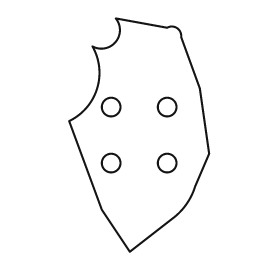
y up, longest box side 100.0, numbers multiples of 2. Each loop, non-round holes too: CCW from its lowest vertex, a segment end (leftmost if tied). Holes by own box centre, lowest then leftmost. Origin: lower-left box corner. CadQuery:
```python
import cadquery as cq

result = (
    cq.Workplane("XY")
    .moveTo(26.0, 0.0)
    .lineTo(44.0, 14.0)
    .threePointArc((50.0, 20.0), (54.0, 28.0))
    .lineTo(60.0, 42.0)
    .lineTo(56.0, 70.0)
    .lineTo(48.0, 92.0)
    .threePointArc((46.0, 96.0), (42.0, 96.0))
    .lineTo(20.0, 100.0)
    .threePointArc((20.0, 90.0), (10.0, 88.0))
    .threePointArc((12.0, 70.0), (0.0, 56.0))
    .lineTo(14.0, 18.0)
    .close()
    .moveTo(18.0, 38.0)
    .circle(4.0)
    .moveTo(42.0, 38.0)
    .circle(4.0)
    .moveTo(18.0, 62.0)
    .circle(4.0)
    .moveTo(42.0, 62.0)
    .circle(4.0)
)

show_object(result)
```